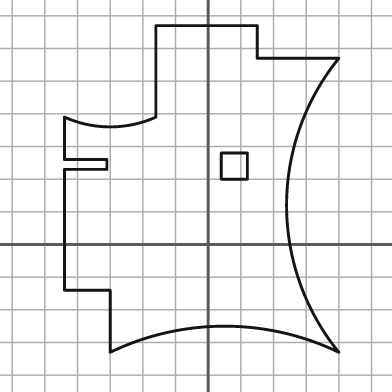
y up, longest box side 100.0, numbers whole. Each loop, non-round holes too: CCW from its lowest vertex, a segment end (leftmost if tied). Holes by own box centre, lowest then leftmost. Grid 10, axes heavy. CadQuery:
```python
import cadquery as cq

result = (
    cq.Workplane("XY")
    .moveTo(-30.0, -33.0)
    .threePointArc((5.0, -25.0), (40.0, -33.0))
    .threePointArc((24.0, 12.0), (40.0, 57.0))
    .lineTo(15.0, 57.0)
    .lineTo(15.0, 67.0)
    .lineTo(-16.0, 67.0)
    .lineTo(-16.0, 39.0)
    .threePointArc((-30.0, 36.0), (-44.0, 39.0))
    .lineTo(-44.0, 26.0)
    .lineTo(-31.0, 26.0)
    .lineTo(-31.0, 23.0)
    .lineTo(-44.0, 23.0)
    .lineTo(-44.0, -14.0)
    .lineTo(-30.0, -14.0)
    .close()
    .moveTo(4.0, 20.0)
    .lineTo(12.0, 20.0)
    .lineTo(12.0, 28.0)
    .lineTo(4.0, 28.0)
    .close()
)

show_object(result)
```